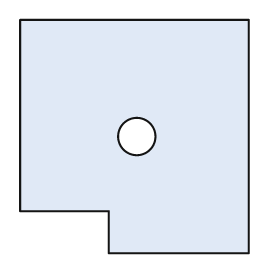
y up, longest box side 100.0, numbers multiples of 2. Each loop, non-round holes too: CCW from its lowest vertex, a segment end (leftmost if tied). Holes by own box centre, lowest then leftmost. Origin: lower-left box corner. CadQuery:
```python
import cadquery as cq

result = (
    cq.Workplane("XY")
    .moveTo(38.0, 0.0)
    .lineTo(98.0, 0.0)
    .lineTo(98.0, 100.0)
    .lineTo(0.0, 100.0)
    .lineTo(0.0, 18.0)
    .lineTo(38.0, 18.0)
    .close()
    .moveTo(50.0, 50.0)
    .circle(8.0)
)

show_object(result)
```